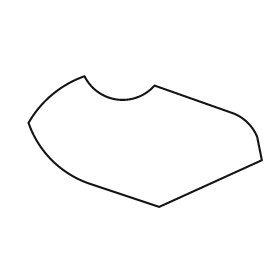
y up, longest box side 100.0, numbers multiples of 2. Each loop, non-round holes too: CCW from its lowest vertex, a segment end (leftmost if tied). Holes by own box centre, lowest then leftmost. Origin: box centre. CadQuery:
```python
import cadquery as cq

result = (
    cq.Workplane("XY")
    .moveTo(6.0, -28.0)
    .lineTo(50.0, -8.0)
    .lineTo(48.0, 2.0)
    .threePointArc((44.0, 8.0), (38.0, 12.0))
    .lineTo(4.0, 24.0)
    .threePointArc((-12.0, 18.0), (-26.0, 28.0))
    .threePointArc((-40.0, 20.0), (-50.0, 8.0))
    .threePointArc((-40.0, -8.0), (-24.0, -18.0))
    .close()
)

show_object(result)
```